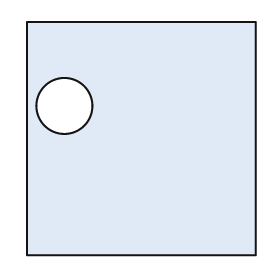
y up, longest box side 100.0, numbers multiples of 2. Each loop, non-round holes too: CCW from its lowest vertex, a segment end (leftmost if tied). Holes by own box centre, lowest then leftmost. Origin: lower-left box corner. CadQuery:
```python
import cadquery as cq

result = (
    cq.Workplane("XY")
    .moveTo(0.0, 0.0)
    .lineTo(98.0, 0.0)
    .lineTo(98.0, 100.0)
    .lineTo(0.0, 100.0)
    .close()
    .moveTo(16.0, 64.0)
    .circle(12.0)
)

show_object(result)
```